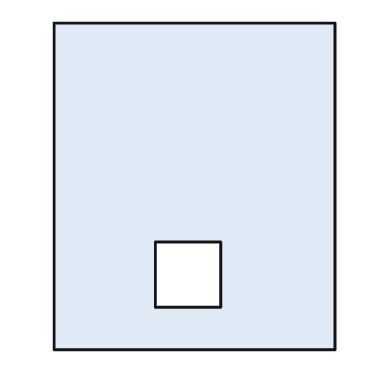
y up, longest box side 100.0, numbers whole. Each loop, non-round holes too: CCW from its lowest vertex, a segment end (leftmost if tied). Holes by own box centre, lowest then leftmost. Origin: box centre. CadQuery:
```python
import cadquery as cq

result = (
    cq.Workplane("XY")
    .moveTo(-43.0, -50.0)
    .lineTo(43.0, -50.0)
    .lineTo(43.0, 50.0)
    .lineTo(-43.0, 50.0)
    .close()
    .moveTo(-12.0, -37.0)
    .lineTo(8.0, -37.0)
    .lineTo(8.0, -17.0)
    .lineTo(-12.0, -17.0)
    .close()
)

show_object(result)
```